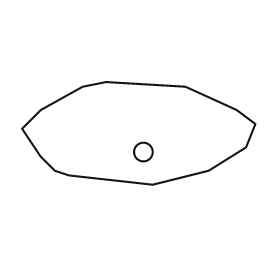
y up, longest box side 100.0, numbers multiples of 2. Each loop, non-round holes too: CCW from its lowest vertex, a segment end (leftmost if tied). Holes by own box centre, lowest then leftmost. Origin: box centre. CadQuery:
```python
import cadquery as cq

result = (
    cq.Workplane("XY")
    .moveTo(6.0, -22.0)
    .lineTo(30.0, -16.0)
    .lineTo(46.0, -6.0)
    .lineTo(50.0, 4.0)
    .lineTo(42.0, 10.0)
    .lineTo(20.0, 20.0)
    .lineTo(-14.0, 22.0)
    .lineTo(-24.0, 20.0)
    .lineTo(-42.0, 10.0)
    .lineTo(-50.0, 2.0)
    .lineTo(-42.0, -10.0)
    .lineTo(-36.0, -16.0)
    .lineTo(-30.0, -18.0)
    .close()
    .moveTo(2.0, -8.0)
    .circle(4.0)
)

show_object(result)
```